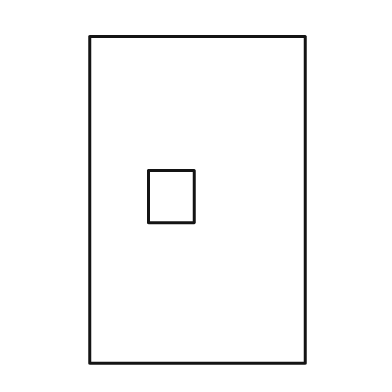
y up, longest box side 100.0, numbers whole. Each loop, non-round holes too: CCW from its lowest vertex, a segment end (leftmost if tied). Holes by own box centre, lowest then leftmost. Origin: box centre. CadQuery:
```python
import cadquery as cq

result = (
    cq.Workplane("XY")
    .moveTo(-33.0, -50.0)
    .lineTo(33.0, -50.0)
    .lineTo(33.0, 50.0)
    .lineTo(-33.0, 50.0)
    .close()
    .moveTo(-15.0, -7.0)
    .lineTo(-1.0, -7.0)
    .lineTo(-1.0, 9.0)
    .lineTo(-15.0, 9.0)
    .close()
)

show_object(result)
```